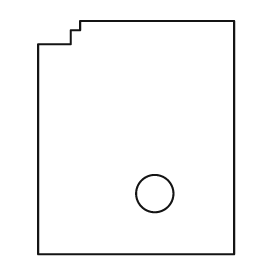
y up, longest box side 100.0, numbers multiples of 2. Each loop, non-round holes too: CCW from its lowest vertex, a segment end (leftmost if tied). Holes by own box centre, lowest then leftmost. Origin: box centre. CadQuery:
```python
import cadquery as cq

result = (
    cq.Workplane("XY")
    .moveTo(-42.0, -50.0)
    .lineTo(42.0, -50.0)
    .lineTo(42.0, 50.0)
    .lineTo(-24.0, 50.0)
    .lineTo(-24.0, 46.0)
    .lineTo(-28.0, 46.0)
    .lineTo(-28.0, 40.0)
    .lineTo(-42.0, 40.0)
    .close()
    .moveTo(8.0, -24.0)
    .circle(8.0)
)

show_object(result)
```